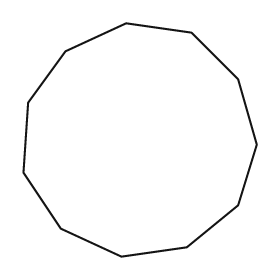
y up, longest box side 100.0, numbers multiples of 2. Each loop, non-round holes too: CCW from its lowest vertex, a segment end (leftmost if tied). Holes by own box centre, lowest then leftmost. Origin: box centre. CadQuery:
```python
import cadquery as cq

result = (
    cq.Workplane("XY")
    .moveTo(-8.0, -50.0)
    .lineTo(20.0, -46.0)
    .lineTo(42.0, -28.0)
    .lineTo(50.0, -2.0)
    .lineTo(42.0, 26.0)
    .lineTo(22.0, 46.0)
    .lineTo(-6.0, 50.0)
    .lineTo(-32.0, 38.0)
    .lineTo(-48.0, 16.0)
    .lineTo(-50.0, -14.0)
    .lineTo(-34.0, -38.0)
    .close()
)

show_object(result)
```